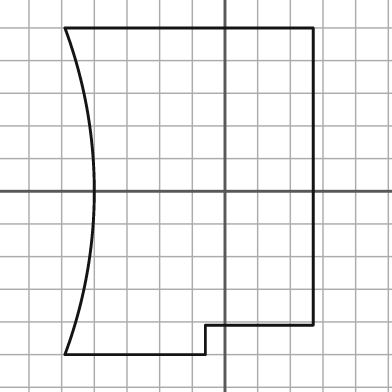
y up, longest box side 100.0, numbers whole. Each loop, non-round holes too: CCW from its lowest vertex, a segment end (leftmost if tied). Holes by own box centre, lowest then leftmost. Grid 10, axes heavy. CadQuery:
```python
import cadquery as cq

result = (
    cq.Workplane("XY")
    .moveTo(-49.0, -50.0)
    .lineTo(-6.0, -50.0)
    .lineTo(-6.0, -41.0)
    .lineTo(27.0, -41.0)
    .lineTo(27.0, 50.0)
    .lineTo(-49.0, 50.0)
    .threePointArc((-40.0, 0.0), (-49.0, -50.0))
    .close()
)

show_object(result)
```